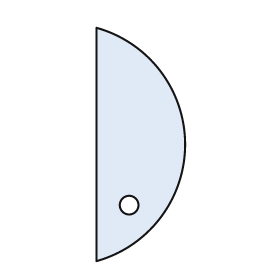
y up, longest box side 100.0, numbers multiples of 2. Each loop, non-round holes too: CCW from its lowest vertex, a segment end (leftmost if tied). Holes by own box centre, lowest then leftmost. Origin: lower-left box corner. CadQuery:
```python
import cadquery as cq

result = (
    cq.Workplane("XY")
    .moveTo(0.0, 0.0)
    .threePointArc((38.0, 50.0), (0.0, 100.0))
    .close()
    .moveTo(14.0, 24.0)
    .circle(4.0)
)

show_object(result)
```